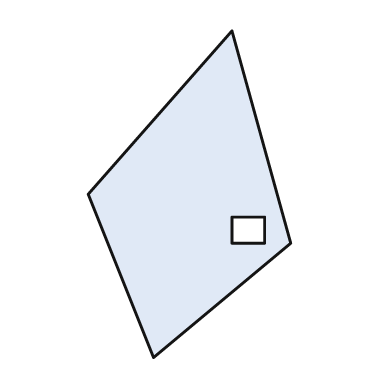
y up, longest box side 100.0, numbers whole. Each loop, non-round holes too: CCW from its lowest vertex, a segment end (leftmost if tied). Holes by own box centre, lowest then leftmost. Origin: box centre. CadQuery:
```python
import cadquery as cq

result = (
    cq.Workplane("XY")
    .moveTo(-11.0, -50.0)
    .lineTo(31.0, -15.0)
    .lineTo(13.0, 50.0)
    .lineTo(-31.0, 0.0)
    .close()
    .moveTo(13.0, -15.0)
    .lineTo(23.0, -15.0)
    .lineTo(23.0, -7.0)
    .lineTo(13.0, -7.0)
    .close()
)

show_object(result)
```